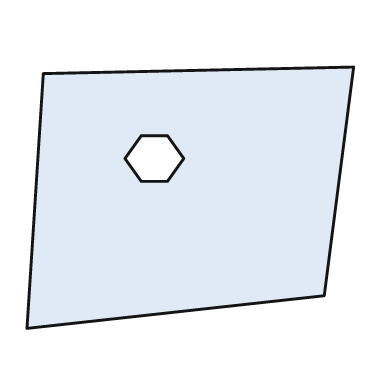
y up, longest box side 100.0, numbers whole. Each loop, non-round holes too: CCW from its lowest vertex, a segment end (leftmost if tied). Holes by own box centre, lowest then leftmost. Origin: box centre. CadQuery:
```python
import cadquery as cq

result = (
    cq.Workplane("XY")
    .moveTo(-50.0, -40.0)
    .lineTo(41.0, -30.0)
    .lineTo(50.0, 40.0)
    .lineTo(-45.0, 38.0)
    .close()
    .moveTo(-15.0, 5.0)
    .lineTo(-7.0, 5.0)
    .lineTo(-2.0, 12.0)
    .lineTo(-7.0, 19.0)
    .lineTo(-15.0, 19.0)
    .lineTo(-20.0, 12.0)
    .close()
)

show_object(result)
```